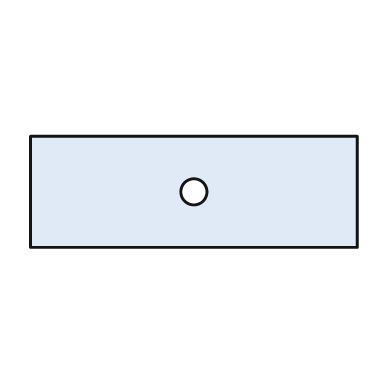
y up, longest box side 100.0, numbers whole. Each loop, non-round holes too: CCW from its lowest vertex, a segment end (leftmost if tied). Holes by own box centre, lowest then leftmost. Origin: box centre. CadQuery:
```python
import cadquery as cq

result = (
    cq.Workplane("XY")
    .moveTo(-50.0, -17.0)
    .lineTo(50.0, -17.0)
    .lineTo(50.0, 17.0)
    .lineTo(-50.0, 17.0)
    .close()
    .moveTo(0.0, 0.0)
    .circle(4.0)
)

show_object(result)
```